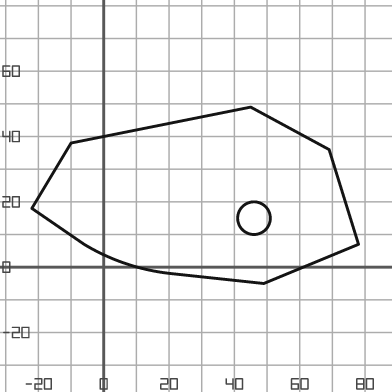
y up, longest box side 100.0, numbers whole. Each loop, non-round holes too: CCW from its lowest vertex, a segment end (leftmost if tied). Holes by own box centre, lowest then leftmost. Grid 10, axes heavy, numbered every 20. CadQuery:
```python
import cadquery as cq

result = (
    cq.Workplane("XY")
    .moveTo(49.0, -5.0)
    .lineTo(78.0, 7.0)
    .lineTo(69.0, 36.0)
    .lineTo(45.0, 49.0)
    .lineTo(-10.0, 38.0)
    .lineTo(-22.0, 18.0)
    .lineTo(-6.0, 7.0)
    .threePointArc((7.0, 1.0), (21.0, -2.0))
    .close()
    .moveTo(46.0, 15.0)
    .circle(5.0)
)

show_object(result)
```